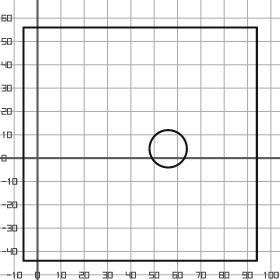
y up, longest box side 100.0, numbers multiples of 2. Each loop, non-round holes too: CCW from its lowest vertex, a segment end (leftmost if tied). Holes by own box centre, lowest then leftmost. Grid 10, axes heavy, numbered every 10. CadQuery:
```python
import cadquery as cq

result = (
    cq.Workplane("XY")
    .moveTo(-6.0, -44.0)
    .lineTo(94.0, -44.0)
    .lineTo(94.0, 56.0)
    .lineTo(-6.0, 56.0)
    .close()
    .moveTo(56.0, 4.0)
    .circle(8.0)
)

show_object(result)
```